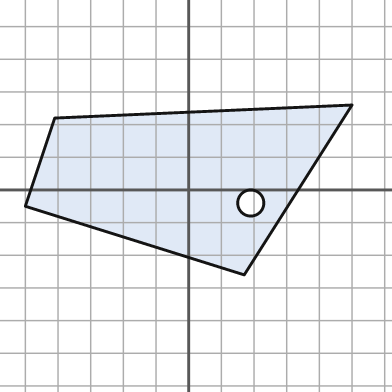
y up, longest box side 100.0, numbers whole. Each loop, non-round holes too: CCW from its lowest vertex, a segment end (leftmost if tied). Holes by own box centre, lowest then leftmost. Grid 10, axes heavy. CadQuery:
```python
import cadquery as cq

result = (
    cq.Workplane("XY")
    .moveTo(17.0, -26.0)
    .lineTo(50.0, 26.0)
    .lineTo(-41.0, 22.0)
    .lineTo(-50.0, -5.0)
    .close()
    .moveTo(19.0, -4.0)
    .circle(4.0)
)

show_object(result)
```